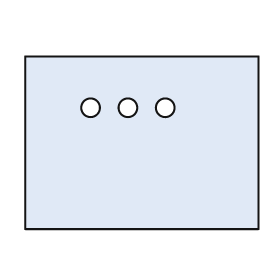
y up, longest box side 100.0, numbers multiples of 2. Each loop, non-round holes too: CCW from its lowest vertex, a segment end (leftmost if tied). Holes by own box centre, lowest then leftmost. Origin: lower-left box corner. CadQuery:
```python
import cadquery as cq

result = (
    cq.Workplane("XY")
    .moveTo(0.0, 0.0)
    .lineTo(100.0, 0.0)
    .lineTo(100.0, 74.0)
    .lineTo(0.0, 74.0)
    .close()
    .moveTo(28.0, 52.0)
    .circle(4.0)
    .moveTo(44.0, 52.0)
    .circle(4.0)
    .moveTo(60.0, 52.0)
    .circle(4.0)
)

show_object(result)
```